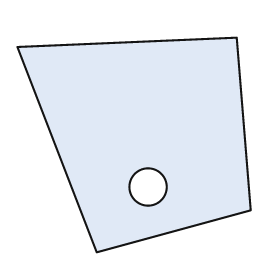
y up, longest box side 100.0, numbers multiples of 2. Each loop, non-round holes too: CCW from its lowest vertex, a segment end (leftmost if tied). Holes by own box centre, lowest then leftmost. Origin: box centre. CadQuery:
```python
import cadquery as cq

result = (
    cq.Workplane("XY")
    .moveTo(-16.0, -46.0)
    .lineTo(50.0, -28.0)
    .lineTo(44.0, 46.0)
    .lineTo(-50.0, 42.0)
    .close()
    .moveTo(6.0, -18.0)
    .circle(8.0)
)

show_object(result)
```